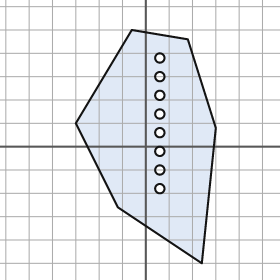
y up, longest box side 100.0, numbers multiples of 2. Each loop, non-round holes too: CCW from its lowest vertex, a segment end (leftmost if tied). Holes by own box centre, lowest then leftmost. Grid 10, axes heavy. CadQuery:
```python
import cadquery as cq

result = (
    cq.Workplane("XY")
    .moveTo(24.0, -50.0)
    .lineTo(30.0, 8.0)
    .lineTo(18.0, 46.0)
    .lineTo(-6.0, 50.0)
    .lineTo(-30.0, 10.0)
    .lineTo(-12.0, -26.0)
    .close()
    .moveTo(6.0, -18.0)
    .circle(2.0)
    .moveTo(6.0, -10.0)
    .circle(2.0)
    .moveTo(6.0, -2.0)
    .circle(2.0)
    .moveTo(6.0, 6.0)
    .circle(2.0)
    .moveTo(6.0, 14.0)
    .circle(2.0)
    .moveTo(6.0, 22.0)
    .circle(2.0)
    .moveTo(6.0, 30.0)
    .circle(2.0)
    .moveTo(6.0, 38.0)
    .circle(2.0)
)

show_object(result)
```